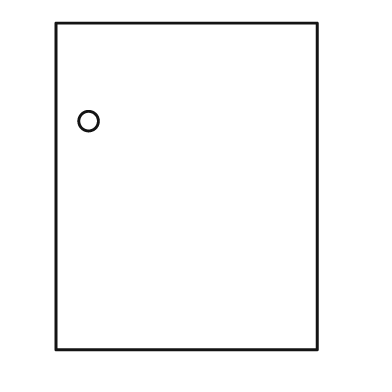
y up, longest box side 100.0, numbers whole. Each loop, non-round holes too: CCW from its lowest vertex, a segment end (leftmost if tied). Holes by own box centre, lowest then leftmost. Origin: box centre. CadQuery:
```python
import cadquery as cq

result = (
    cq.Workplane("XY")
    .moveTo(-40.0, -50.0)
    .lineTo(40.0, -50.0)
    .lineTo(40.0, 50.0)
    .lineTo(-40.0, 50.0)
    .close()
    .moveTo(-30.0, 20.0)
    .circle(3.0)
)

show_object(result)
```